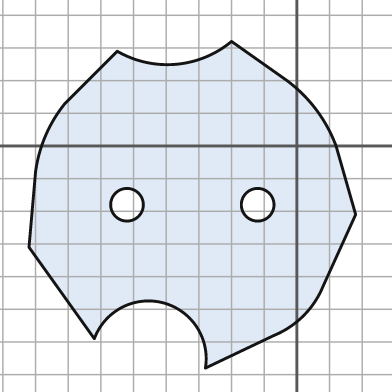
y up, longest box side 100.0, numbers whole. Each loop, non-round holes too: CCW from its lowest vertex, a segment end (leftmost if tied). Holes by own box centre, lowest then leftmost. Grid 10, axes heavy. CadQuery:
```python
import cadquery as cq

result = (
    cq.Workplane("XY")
    .moveTo(-28.0, -68.0)
    .lineTo(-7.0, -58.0)
    .threePointArc((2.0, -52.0), (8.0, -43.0))
    .lineTo(18.0, -21.0)
    .lineTo(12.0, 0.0)
    .threePointArc((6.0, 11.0), (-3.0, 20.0))
    .lineTo(-20.0, 32.0)
    .threePointArc((-37.0, 25.0), (-55.0, 29.0))
    .lineTo(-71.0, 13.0)
    .threePointArc((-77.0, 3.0), (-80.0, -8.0))
    .lineTo(-82.0, -31.0)
    .lineTo(-62.0, -59.0)
    .threePointArc((-41.0, -48.0), (-28.0, -68.0))
    .close()
    .moveTo(-52.0, -18.0)
    .circle(5.0)
    .moveTo(-12.0, -18.0)
    .circle(5.0)
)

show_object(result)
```